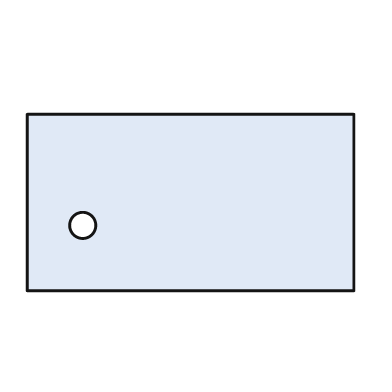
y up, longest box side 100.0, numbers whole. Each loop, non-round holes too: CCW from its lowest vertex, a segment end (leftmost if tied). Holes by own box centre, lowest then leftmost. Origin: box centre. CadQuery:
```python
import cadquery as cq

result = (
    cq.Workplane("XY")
    .moveTo(-50.0, -27.0)
    .lineTo(50.0, -27.0)
    .lineTo(50.0, 27.0)
    .lineTo(-50.0, 27.0)
    .close()
    .moveTo(-33.0, -7.0)
    .circle(4.0)
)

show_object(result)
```